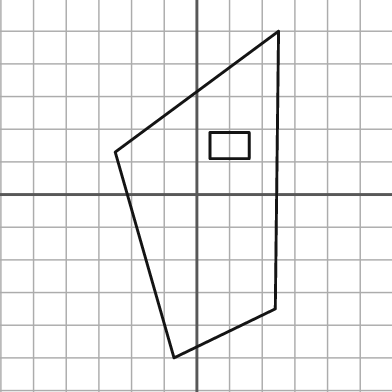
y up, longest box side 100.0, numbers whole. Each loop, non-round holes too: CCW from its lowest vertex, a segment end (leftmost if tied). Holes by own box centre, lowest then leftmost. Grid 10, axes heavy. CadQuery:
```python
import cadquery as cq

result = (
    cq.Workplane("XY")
    .moveTo(-7.0, -50.0)
    .lineTo(24.0, -35.0)
    .lineTo(25.0, 50.0)
    .lineTo(-25.0, 13.0)
    .close()
    .moveTo(4.0, 11.0)
    .lineTo(16.0, 11.0)
    .lineTo(16.0, 19.0)
    .lineTo(4.0, 19.0)
    .close()
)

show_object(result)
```